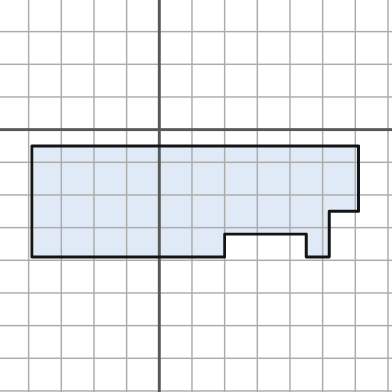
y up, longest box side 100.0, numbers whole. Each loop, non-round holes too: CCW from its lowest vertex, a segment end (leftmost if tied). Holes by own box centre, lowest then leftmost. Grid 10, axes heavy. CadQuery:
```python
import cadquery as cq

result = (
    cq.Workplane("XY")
    .moveTo(-39.0, -39.0)
    .lineTo(20.0, -39.0)
    .lineTo(20.0, -32.0)
    .lineTo(45.0, -32.0)
    .lineTo(45.0, -39.0)
    .lineTo(52.0, -39.0)
    .lineTo(52.0, -25.0)
    .lineTo(61.0, -25.0)
    .lineTo(61.0, -5.0)
    .lineTo(-39.0, -5.0)
    .close()
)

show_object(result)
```